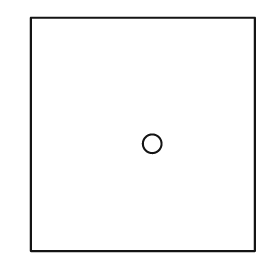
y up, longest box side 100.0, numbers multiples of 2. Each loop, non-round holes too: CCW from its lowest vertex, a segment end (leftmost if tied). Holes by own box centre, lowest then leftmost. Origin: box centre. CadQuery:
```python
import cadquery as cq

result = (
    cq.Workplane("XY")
    .moveTo(-48.0, -50.0)
    .lineTo(48.0, -50.0)
    .lineTo(48.0, 50.0)
    .lineTo(-48.0, 50.0)
    .close()
    .moveTo(4.0, -4.0)
    .circle(4.0)
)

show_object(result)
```